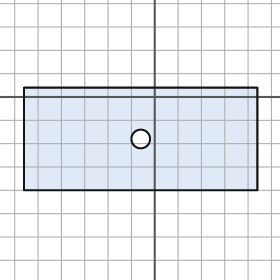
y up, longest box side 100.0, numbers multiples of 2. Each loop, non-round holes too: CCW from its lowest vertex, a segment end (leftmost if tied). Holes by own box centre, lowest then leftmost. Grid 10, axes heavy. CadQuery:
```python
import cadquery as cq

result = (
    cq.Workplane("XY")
    .moveTo(-56.0, -40.0)
    .lineTo(44.0, -40.0)
    .lineTo(44.0, 4.0)
    .lineTo(-56.0, 4.0)
    .close()
    .moveTo(-6.0, -18.0)
    .circle(4.0)
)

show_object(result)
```